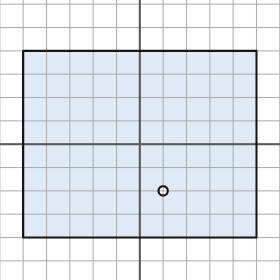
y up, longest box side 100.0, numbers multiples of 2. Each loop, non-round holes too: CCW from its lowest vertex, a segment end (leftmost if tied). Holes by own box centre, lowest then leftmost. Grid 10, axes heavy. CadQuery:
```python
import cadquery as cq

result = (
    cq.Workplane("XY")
    .moveTo(-50.0, -40.0)
    .lineTo(50.0, -40.0)
    .lineTo(50.0, 40.0)
    .lineTo(-50.0, 40.0)
    .close()
    .moveTo(10.0, -20.0)
    .circle(2.0)
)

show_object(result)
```